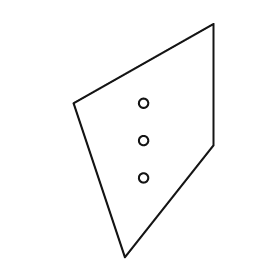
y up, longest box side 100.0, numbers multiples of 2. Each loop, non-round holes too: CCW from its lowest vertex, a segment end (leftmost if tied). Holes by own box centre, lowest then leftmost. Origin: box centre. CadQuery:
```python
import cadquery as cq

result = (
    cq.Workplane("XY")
    .moveTo(-8.0, -50.0)
    .lineTo(30.0, -2.0)
    .lineTo(30.0, 50.0)
    .lineTo(-30.0, 16.0)
    .close()
    .moveTo(0.0, -16.0)
    .circle(2.0)
    .moveTo(0.0, 0.0)
    .circle(2.0)
    .moveTo(0.0, 16.0)
    .circle(2.0)
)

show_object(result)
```